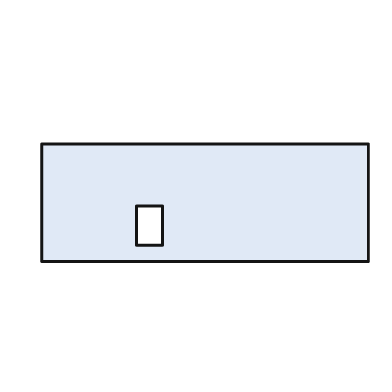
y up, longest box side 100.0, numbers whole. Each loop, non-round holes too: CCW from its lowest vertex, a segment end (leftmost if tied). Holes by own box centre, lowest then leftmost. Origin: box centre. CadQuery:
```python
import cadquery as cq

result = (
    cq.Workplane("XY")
    .moveTo(-50.0, -18.0)
    .lineTo(50.0, -18.0)
    .lineTo(50.0, 18.0)
    .lineTo(-50.0, 18.0)
    .close()
    .moveTo(-21.0, -13.0)
    .lineTo(-13.0, -13.0)
    .lineTo(-13.0, -1.0)
    .lineTo(-21.0, -1.0)
    .close()
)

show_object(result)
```